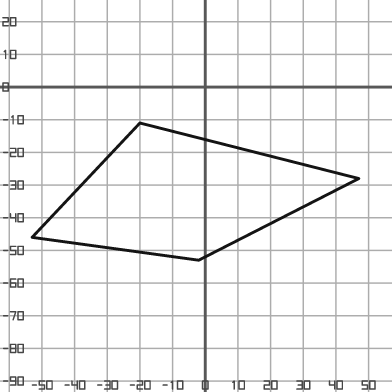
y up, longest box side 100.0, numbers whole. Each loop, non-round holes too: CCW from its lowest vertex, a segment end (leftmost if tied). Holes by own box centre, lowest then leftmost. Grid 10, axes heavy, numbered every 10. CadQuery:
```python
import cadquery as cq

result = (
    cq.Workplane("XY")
    .moveTo(-2.0, -53.0)
    .lineTo(47.0, -28.0)
    .lineTo(-20.0, -11.0)
    .lineTo(-53.0, -46.0)
    .close()
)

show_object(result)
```